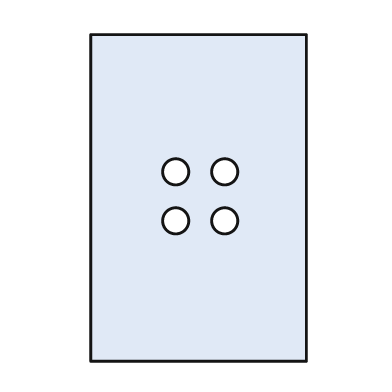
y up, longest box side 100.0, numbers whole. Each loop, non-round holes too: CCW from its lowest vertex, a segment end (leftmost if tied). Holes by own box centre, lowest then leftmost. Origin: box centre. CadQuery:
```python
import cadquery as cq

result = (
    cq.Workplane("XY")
    .moveTo(-33.0, -50.0)
    .lineTo(33.0, -50.0)
    .lineTo(33.0, 50.0)
    .lineTo(-33.0, 50.0)
    .close()
    .moveTo(-7.0, -7.0)
    .circle(4.0)
    .moveTo(8.0, -7.0)
    .circle(4.0)
    .moveTo(-7.0, 8.0)
    .circle(4.0)
    .moveTo(8.0, 8.0)
    .circle(4.0)
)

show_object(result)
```